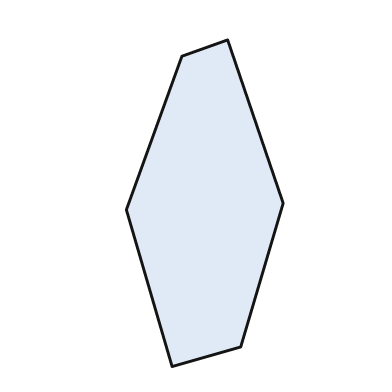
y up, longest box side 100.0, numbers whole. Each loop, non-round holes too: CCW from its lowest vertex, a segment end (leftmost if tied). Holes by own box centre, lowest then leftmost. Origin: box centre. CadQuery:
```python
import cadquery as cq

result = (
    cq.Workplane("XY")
    .moveTo(-10.0, -50.0)
    .lineTo(11.0, -44.0)
    .lineTo(24.0, 0.0)
    .lineTo(7.0, 50.0)
    .lineTo(-7.0, 45.0)
    .lineTo(-24.0, -2.0)
    .close()
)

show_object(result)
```